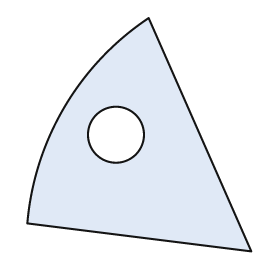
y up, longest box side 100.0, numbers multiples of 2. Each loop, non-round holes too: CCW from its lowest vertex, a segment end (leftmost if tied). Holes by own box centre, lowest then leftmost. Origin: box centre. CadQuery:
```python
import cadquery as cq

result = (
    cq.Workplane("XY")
    .moveTo(48.0, -50.0)
    .lineTo(4.0, 50.0)
    .threePointArc((-32.0, 12.0), (-48.0, -38.0))
    .close()
    .moveTo(-10.0, 0.0)
    .circle(12.0)
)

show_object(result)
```